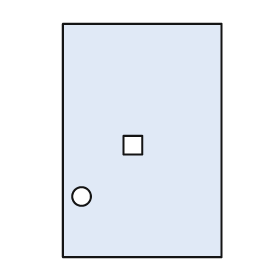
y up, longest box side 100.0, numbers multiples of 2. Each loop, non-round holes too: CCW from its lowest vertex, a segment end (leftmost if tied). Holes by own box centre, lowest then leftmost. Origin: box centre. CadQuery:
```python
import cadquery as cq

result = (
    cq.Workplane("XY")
    .moveTo(-34.0, -50.0)
    .lineTo(34.0, -50.0)
    .lineTo(34.0, 50.0)
    .lineTo(-34.0, 50.0)
    .close()
    .moveTo(-26.0, -24.0)
    .circle(4.0)
    .moveTo(-8.0, -6.0)
    .lineTo(0.0, -6.0)
    .lineTo(0.0, 2.0)
    .lineTo(-8.0, 2.0)
    .close()
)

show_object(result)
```